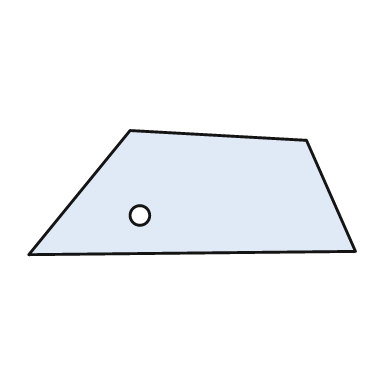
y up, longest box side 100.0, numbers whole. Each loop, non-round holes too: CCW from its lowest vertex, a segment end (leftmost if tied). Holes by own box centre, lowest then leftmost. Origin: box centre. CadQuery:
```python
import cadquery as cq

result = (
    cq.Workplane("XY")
    .moveTo(-50.0, -19.0)
    .lineTo(50.0, -18.0)
    .lineTo(35.0, 16.0)
    .lineTo(-19.0, 19.0)
    .close()
    .moveTo(-16.0, -7.0)
    .circle(3.0)
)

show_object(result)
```